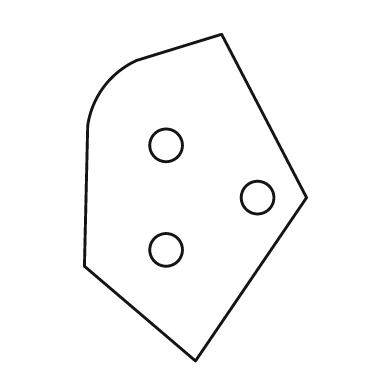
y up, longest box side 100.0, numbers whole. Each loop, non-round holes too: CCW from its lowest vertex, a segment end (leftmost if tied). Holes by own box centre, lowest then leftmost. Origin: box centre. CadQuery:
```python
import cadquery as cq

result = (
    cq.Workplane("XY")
    .moveTo(0.0, -50.0)
    .lineTo(34.0, 0.0)
    .lineTo(8.0, 50.0)
    .lineTo(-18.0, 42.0)
    .threePointArc((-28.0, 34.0), (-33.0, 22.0))
    .lineTo(-34.0, -21.0)
    .close()
    .moveTo(-9.0, -16.0)
    .circle(5.0)
    .moveTo(19.0, 0.0)
    .circle(5.0)
    .moveTo(-9.0, 16.0)
    .circle(5.0)
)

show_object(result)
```